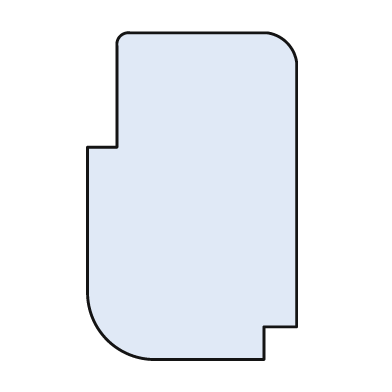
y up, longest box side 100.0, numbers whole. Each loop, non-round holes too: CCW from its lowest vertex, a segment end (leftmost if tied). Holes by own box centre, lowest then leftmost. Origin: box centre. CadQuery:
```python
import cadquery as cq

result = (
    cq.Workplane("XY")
    .moveTo(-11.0, -50.0)
    .lineTo(22.0, -50.0)
    .lineTo(22.0, -40.0)
    .lineTo(32.0, -40.0)
    .lineTo(32.0, 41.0)
    .threePointArc((29.0, 47.0), (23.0, 50.0))
    .lineTo(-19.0, 50.0)
    .threePointArc((-22.0, 49.0), (-23.0, 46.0))
    .lineTo(-23.0, 15.0)
    .lineTo(-32.0, 15.0)
    .lineTo(-32.0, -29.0)
    .threePointArc((-26.0, -44.0), (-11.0, -50.0))
    .close()
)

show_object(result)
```